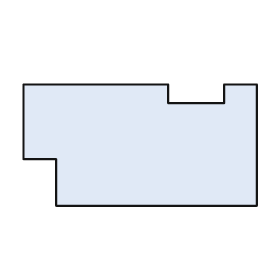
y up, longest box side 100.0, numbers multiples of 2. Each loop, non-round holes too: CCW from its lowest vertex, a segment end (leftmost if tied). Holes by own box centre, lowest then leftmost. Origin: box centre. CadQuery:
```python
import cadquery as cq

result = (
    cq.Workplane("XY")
    .moveTo(-36.0, -26.0)
    .lineTo(50.0, -26.0)
    .lineTo(50.0, 26.0)
    .lineTo(36.0, 26.0)
    .lineTo(36.0, 18.0)
    .lineTo(12.0, 18.0)
    .lineTo(12.0, 26.0)
    .lineTo(-50.0, 26.0)
    .lineTo(-50.0, -6.0)
    .lineTo(-36.0, -6.0)
    .close()
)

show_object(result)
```